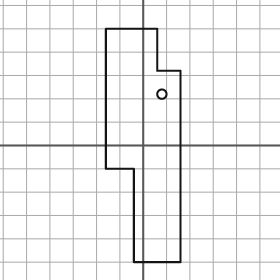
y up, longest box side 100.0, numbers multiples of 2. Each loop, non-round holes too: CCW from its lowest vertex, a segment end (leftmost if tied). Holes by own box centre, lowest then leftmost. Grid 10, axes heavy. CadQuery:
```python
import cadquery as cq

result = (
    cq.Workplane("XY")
    .moveTo(-4.0, -50.0)
    .lineTo(16.0, -50.0)
    .lineTo(16.0, 32.0)
    .lineTo(6.0, 32.0)
    .lineTo(6.0, 50.0)
    .lineTo(-16.0, 50.0)
    .lineTo(-16.0, -10.0)
    .lineTo(-4.0, -10.0)
    .close()
    .moveTo(8.0, 22.0)
    .circle(2.0)
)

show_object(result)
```